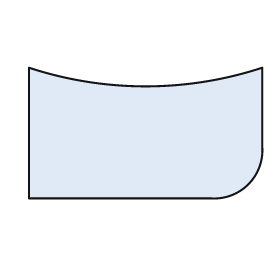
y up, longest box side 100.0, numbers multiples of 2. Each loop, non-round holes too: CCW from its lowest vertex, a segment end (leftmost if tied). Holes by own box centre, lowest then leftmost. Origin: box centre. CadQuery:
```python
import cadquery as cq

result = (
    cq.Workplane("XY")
    .moveTo(-50.0, -28.0)
    .lineTo(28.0, -28.0)
    .threePointArc((44.0, -22.0), (50.0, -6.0))
    .lineTo(50.0, 28.0)
    .threePointArc((0.0, 20.0), (-50.0, 28.0))
    .close()
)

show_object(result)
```